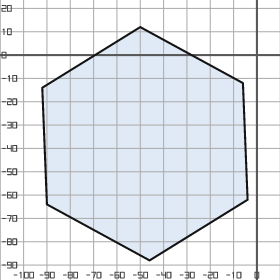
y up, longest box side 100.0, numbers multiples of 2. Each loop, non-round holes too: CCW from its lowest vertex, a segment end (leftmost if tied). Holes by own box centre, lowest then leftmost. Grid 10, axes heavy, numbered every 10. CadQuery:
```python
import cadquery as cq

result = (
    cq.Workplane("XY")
    .moveTo(-46.0, -88.0)
    .lineTo(-4.0, -62.0)
    .lineTo(-6.0, -12.0)
    .lineTo(-50.0, 12.0)
    .lineTo(-92.0, -14.0)
    .lineTo(-90.0, -64.0)
    .close()
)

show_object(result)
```